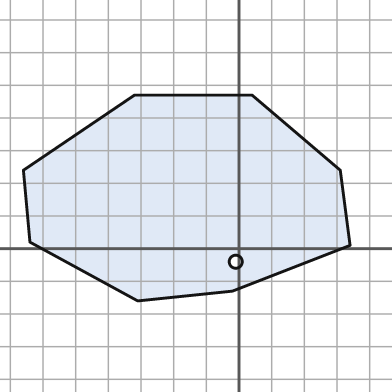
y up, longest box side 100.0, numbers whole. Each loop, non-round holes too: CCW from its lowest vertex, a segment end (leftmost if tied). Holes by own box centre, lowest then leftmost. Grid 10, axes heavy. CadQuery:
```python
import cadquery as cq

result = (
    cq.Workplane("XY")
    .moveTo(-31.0, -16.0)
    .lineTo(-2.0, -13.0)
    .lineTo(34.0, 1.0)
    .lineTo(31.0, 24.0)
    .lineTo(4.0, 47.0)
    .lineTo(-32.0, 47.0)
    .lineTo(-66.0, 24.0)
    .lineTo(-64.0, 2.0)
    .close()
    .moveTo(-1.0, -4.0)
    .circle(2.0)
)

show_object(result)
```